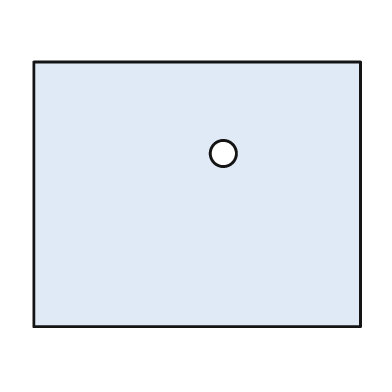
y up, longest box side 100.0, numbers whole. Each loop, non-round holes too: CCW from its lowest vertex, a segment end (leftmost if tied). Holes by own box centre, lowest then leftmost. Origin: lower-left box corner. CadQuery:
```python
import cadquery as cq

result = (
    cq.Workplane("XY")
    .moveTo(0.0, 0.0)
    .lineTo(100.0, 0.0)
    .lineTo(100.0, 81.0)
    .lineTo(0.0, 81.0)
    .close()
    .moveTo(58.0, 53.0)
    .circle(4.0)
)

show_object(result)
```